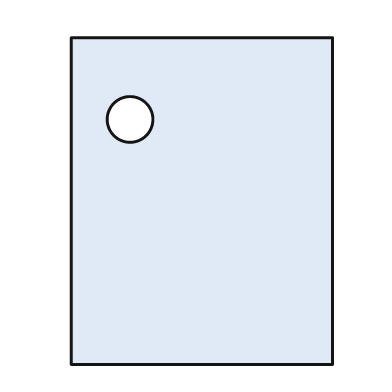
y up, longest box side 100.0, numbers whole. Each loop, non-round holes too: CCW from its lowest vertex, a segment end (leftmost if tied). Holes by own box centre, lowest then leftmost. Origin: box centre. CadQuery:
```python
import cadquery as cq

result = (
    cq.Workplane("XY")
    .moveTo(-40.0, -50.0)
    .lineTo(40.0, -50.0)
    .lineTo(40.0, 50.0)
    .lineTo(-40.0, 50.0)
    .close()
    .moveTo(-22.0, 25.0)
    .circle(7.0)
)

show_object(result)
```